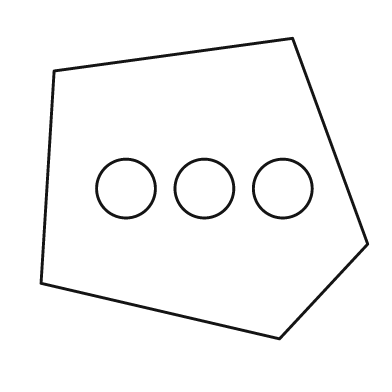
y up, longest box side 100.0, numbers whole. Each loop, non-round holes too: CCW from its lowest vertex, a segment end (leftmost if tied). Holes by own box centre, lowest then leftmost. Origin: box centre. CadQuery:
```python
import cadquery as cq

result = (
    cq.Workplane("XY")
    .moveTo(23.0, -46.0)
    .lineTo(50.0, -17.0)
    .lineTo(27.0, 46.0)
    .lineTo(-46.0, 36.0)
    .lineTo(-50.0, -29.0)
    .close()
    .moveTo(-24.0, 0.0)
    .circle(9.0)
    .moveTo(0.0, 0.0)
    .circle(9.0)
    .moveTo(24.0, 0.0)
    .circle(9.0)
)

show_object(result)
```